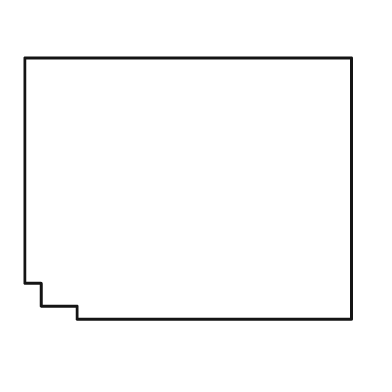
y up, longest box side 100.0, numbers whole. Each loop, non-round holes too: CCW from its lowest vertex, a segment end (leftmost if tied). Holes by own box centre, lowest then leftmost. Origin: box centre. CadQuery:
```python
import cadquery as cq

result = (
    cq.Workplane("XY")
    .moveTo(-34.0, -40.0)
    .lineTo(50.0, -40.0)
    .lineTo(50.0, 40.0)
    .lineTo(-50.0, 40.0)
    .lineTo(-50.0, -29.0)
    .lineTo(-45.0, -29.0)
    .lineTo(-45.0, -36.0)
    .lineTo(-34.0, -36.0)
    .close()
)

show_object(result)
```